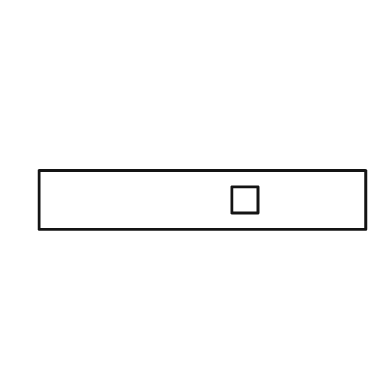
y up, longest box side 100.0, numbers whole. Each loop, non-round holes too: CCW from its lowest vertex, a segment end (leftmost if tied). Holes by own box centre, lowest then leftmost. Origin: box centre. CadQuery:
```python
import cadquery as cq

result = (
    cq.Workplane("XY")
    .moveTo(-50.0, -9.0)
    .lineTo(50.0, -9.0)
    .lineTo(50.0, 9.0)
    .lineTo(-50.0, 9.0)
    .close()
    .moveTo(9.0, -4.0)
    .lineTo(17.0, -4.0)
    .lineTo(17.0, 4.0)
    .lineTo(9.0, 4.0)
    .close()
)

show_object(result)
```